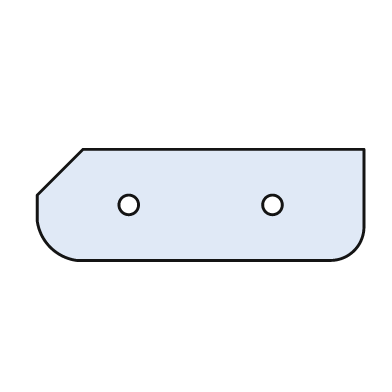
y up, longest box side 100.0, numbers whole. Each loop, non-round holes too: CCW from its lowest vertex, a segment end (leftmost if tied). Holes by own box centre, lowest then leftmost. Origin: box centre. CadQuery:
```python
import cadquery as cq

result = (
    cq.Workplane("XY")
    .moveTo(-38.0, -17.0)
    .lineTo(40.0, -17.0)
    .threePointArc((47.0, -14.0), (50.0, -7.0))
    .lineTo(50.0, 17.0)
    .lineTo(-36.0, 17.0)
    .lineTo(-50.0, 3.0)
    .lineTo(-50.0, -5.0)
    .threePointArc((-46.0, -13.0), (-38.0, -17.0))
    .close()
    .moveTo(-22.0, 0.0)
    .circle(3.0)
    .moveTo(22.0, 0.0)
    .circle(3.0)
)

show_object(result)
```